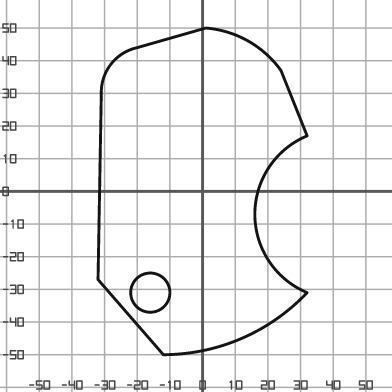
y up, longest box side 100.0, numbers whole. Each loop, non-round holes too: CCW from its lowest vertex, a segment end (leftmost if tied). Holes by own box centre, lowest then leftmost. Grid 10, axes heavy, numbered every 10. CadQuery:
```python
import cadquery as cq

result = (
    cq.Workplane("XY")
    .moveTo(-12.0, -50.0)
    .threePointArc((12.0, -45.0), (32.0, -31.0))
    .threePointArc((16.0, -7.0), (32.0, 17.0))
    .lineTo(24.0, 37.0)
    .threePointArc((14.0, 46.0), (1.0, 50.0))
    .lineTo(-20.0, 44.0)
    .threePointArc((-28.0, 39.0), (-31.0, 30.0))
    .lineTo(-32.0, -27.0)
    .close()
    .moveTo(-16.0, -31.0)
    .circle(6.0)
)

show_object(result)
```